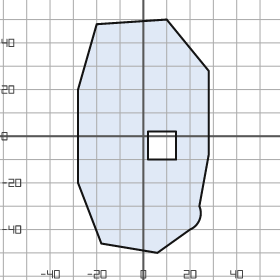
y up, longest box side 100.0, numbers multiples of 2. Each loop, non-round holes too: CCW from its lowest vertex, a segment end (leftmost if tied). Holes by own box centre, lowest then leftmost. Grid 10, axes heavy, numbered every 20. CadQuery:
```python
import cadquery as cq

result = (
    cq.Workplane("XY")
    .moveTo(6.0, -50.0)
    .lineTo(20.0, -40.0)
    .threePointArc((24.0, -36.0), (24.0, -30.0))
    .lineTo(28.0, -8.0)
    .lineTo(28.0, 28.0)
    .lineTo(10.0, 50.0)
    .lineTo(-20.0, 48.0)
    .lineTo(-28.0, 20.0)
    .lineTo(-28.0, -20.0)
    .lineTo(-18.0, -46.0)
    .close()
    .moveTo(2.0, -10.0)
    .lineTo(14.0, -10.0)
    .lineTo(14.0, 2.0)
    .lineTo(2.0, 2.0)
    .close()
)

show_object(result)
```